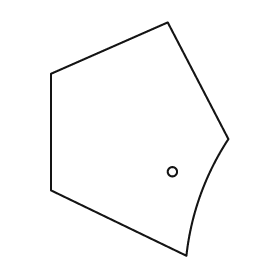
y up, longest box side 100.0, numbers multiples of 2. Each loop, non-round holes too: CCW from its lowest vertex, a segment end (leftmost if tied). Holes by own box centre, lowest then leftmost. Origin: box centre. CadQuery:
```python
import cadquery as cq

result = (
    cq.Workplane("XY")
    .moveTo(20.0, -50.0)
    .threePointArc((26.0, -24.0), (38.0, 0.0))
    .lineTo(12.0, 50.0)
    .lineTo(-38.0, 28.0)
    .lineTo(-38.0, -22.0)
    .close()
    .moveTo(14.0, -14.0)
    .circle(2.0)
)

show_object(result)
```